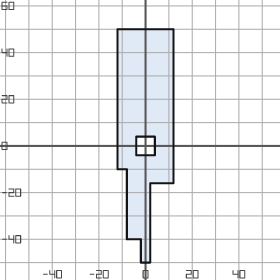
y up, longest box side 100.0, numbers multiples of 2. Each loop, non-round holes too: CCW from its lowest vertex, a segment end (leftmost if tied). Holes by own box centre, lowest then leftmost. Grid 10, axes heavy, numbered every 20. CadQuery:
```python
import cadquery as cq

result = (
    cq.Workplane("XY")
    .moveTo(-2.0, -50.0)
    .lineTo(2.0, -50.0)
    .lineTo(2.0, -16.0)
    .lineTo(12.0, -16.0)
    .lineTo(12.0, 50.0)
    .lineTo(-12.0, 50.0)
    .lineTo(-12.0, -10.0)
    .lineTo(-8.0, -10.0)
    .lineTo(-8.0, -40.0)
    .lineTo(-2.0, -40.0)
    .close()
    .moveTo(-4.0, -4.0)
    .lineTo(4.0, -4.0)
    .lineTo(4.0, 4.0)
    .lineTo(-4.0, 4.0)
    .close()
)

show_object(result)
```